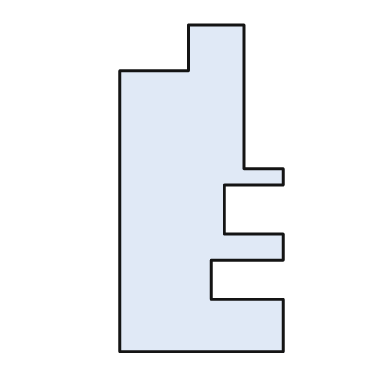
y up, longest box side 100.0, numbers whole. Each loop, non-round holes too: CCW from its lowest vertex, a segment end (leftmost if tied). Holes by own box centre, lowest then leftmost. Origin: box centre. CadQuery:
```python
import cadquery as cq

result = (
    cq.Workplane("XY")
    .moveTo(-25.0, -50.0)
    .lineTo(25.0, -50.0)
    .lineTo(25.0, -34.0)
    .lineTo(3.0, -34.0)
    .lineTo(3.0, -22.0)
    .lineTo(25.0, -22.0)
    .lineTo(25.0, -14.0)
    .lineTo(7.0, -14.0)
    .lineTo(7.0, 1.0)
    .lineTo(25.0, 1.0)
    .lineTo(25.0, 6.0)
    .lineTo(13.0, 6.0)
    .lineTo(13.0, 50.0)
    .lineTo(-4.0, 50.0)
    .lineTo(-4.0, 36.0)
    .lineTo(-25.0, 36.0)
    .close()
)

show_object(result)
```